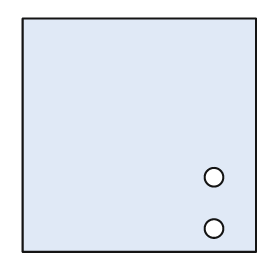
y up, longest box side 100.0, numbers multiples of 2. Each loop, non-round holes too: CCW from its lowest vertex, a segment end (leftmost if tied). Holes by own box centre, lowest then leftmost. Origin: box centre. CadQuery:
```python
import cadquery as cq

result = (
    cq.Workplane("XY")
    .moveTo(-50.0, -50.0)
    .lineTo(50.0, -50.0)
    .lineTo(50.0, 50.0)
    .lineTo(-50.0, 50.0)
    .close()
    .moveTo(32.0, -40.0)
    .circle(4.0)
    .moveTo(32.0, -18.0)
    .circle(4.0)
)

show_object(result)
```